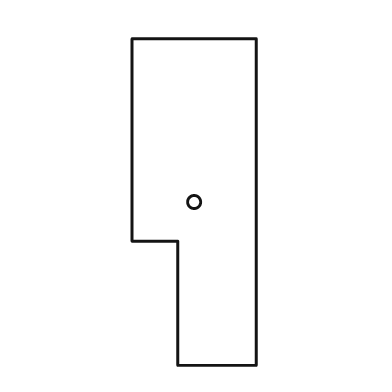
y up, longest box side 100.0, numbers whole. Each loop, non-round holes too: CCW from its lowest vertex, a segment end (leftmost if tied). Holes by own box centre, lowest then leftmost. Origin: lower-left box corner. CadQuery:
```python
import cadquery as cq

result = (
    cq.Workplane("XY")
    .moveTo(14.0, 0.0)
    .lineTo(38.0, 0.0)
    .lineTo(38.0, 100.0)
    .lineTo(0.0, 100.0)
    .lineTo(0.0, 38.0)
    .lineTo(14.0, 38.0)
    .close()
    .moveTo(19.0, 50.0)
    .circle(2.0)
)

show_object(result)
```